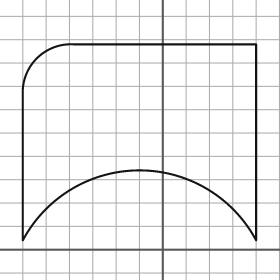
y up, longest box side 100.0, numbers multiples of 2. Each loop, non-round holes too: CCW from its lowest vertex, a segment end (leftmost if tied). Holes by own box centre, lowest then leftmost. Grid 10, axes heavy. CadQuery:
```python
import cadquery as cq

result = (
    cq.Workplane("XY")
    .moveTo(-60.0, 4.0)
    .threePointArc((-10.0, 34.0), (40.0, 4.0))
    .lineTo(40.0, 88.0)
    .lineTo(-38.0, 88.0)
    .threePointArc((-54.0, 82.0), (-60.0, 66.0))
    .close()
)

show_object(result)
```